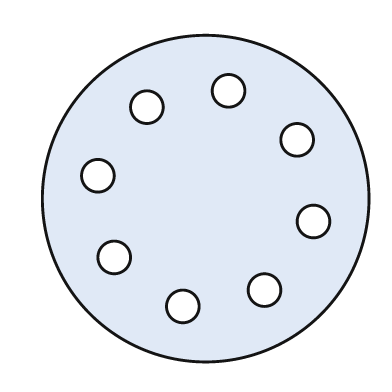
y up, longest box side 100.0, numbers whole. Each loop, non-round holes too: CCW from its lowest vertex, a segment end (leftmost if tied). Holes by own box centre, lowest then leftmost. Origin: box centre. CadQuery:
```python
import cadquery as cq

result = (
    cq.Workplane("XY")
    .moveTo(0.0, 0.0)
    .circle(50.0)
    .moveTo(-7.0, -33.0)
    .circle(5.0)
    .moveTo(18.0, -28.0)
    .circle(5.0)
    .moveTo(-28.0, -18.0)
    .circle(5.0)
    .moveTo(33.0, -7.0)
    .circle(5.0)
    .moveTo(-33.0, 7.0)
    .circle(5.0)
    .moveTo(28.0, 18.0)
    .circle(5.0)
    .moveTo(-18.0, 28.0)
    .circle(5.0)
    .moveTo(7.0, 33.0)
    .circle(5.0)
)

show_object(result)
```